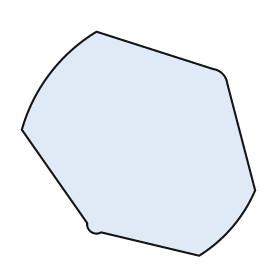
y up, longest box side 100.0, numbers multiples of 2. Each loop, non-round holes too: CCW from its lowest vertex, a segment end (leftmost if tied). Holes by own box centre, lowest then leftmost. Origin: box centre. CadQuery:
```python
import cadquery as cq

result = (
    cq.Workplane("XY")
    .moveTo(26.0, -48.0)
    .threePointArc((40.0, -36.0), (50.0, -20.0))
    .lineTo(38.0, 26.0)
    .threePointArc((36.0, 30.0), (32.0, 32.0))
    .lineTo(-18.0, 48.0)
    .threePointArc((-38.0, 30.0), (-50.0, 6.0))
    .lineTo(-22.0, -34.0)
    .threePointArc((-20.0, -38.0), (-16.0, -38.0))
    .close()
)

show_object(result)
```